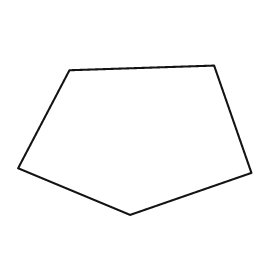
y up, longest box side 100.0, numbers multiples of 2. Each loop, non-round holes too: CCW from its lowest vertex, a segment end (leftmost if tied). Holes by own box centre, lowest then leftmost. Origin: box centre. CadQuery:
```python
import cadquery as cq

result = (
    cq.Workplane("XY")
    .moveTo(-2.0, -32.0)
    .lineTo(50.0, -14.0)
    .lineTo(34.0, 32.0)
    .lineTo(-28.0, 30.0)
    .lineTo(-50.0, -12.0)
    .close()
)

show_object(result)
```